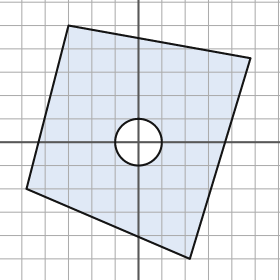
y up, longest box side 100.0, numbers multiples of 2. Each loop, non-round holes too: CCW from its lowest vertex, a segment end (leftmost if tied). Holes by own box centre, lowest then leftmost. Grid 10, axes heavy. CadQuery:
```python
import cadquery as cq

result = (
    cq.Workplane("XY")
    .moveTo(22.0, -50.0)
    .lineTo(48.0, 36.0)
    .lineTo(-30.0, 50.0)
    .lineTo(-48.0, -20.0)
    .close()
    .moveTo(0.0, 0.0)
    .circle(10.0)
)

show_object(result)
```